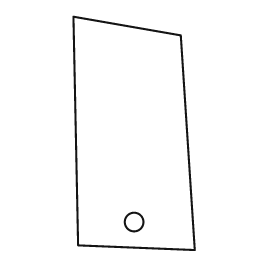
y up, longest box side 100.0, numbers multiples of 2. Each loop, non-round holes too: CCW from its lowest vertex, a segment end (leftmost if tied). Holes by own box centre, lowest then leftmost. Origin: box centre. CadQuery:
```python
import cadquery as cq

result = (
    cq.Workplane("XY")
    .moveTo(26.0, -50.0)
    .lineTo(20.0, 42.0)
    .lineTo(-26.0, 50.0)
    .lineTo(-24.0, -48.0)
    .close()
    .moveTo(0.0, -38.0)
    .circle(4.0)
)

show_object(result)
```